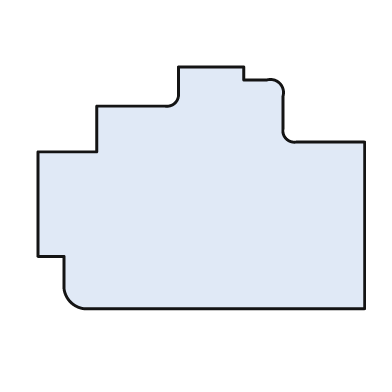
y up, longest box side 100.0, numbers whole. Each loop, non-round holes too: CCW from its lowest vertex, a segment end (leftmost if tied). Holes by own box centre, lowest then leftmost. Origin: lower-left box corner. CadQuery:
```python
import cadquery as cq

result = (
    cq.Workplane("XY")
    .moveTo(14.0, 0.0)
    .lineTo(100.0, 0.0)
    .lineTo(100.0, 51.0)
    .lineTo(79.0, 51.0)
    .threePointArc((76.0, 52.0), (75.0, 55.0))
    .lineTo(75.0, 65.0)
    .threePointArc((74.0, 69.0), (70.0, 70.0))
    .lineTo(63.0, 70.0)
    .lineTo(63.0, 74.0)
    .lineTo(43.0, 74.0)
    .lineTo(43.0, 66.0)
    .threePointArc((42.0, 63.0), (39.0, 62.0))
    .lineTo(18.0, 62.0)
    .lineTo(18.0, 48.0)
    .lineTo(0.0, 48.0)
    .lineTo(0.0, 16.0)
    .lineTo(8.0, 16.0)
    .lineTo(8.0, 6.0)
    .threePointArc((10.0, 2.0), (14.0, 0.0))
    .close()
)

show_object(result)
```